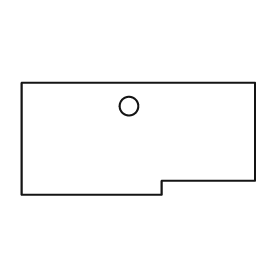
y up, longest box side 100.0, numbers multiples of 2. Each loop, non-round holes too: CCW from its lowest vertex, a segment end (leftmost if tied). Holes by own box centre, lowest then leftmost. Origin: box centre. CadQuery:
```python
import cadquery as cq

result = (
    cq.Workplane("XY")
    .moveTo(-50.0, -24.0)
    .lineTo(10.0, -24.0)
    .lineTo(10.0, -18.0)
    .lineTo(50.0, -18.0)
    .lineTo(50.0, 24.0)
    .lineTo(-50.0, 24.0)
    .close()
    .moveTo(-4.0, 14.0)
    .circle(4.0)
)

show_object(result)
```